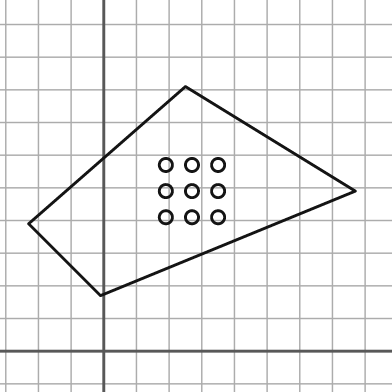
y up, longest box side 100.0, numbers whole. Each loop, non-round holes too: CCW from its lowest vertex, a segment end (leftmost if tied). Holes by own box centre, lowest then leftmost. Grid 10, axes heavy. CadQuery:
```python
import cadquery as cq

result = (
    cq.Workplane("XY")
    .moveTo(-1.0, 17.0)
    .lineTo(77.0, 49.0)
    .lineTo(25.0, 81.0)
    .lineTo(-23.0, 39.0)
    .close()
    .moveTo(19.0, 41.0)
    .circle(2.0)
    .moveTo(27.0, 41.0)
    .circle(2.0)
    .moveTo(35.0, 41.0)
    .circle(2.0)
    .moveTo(19.0, 49.0)
    .circle(2.0)
    .moveTo(27.0, 49.0)
    .circle(2.0)
    .moveTo(35.0, 49.0)
    .circle(2.0)
    .moveTo(19.0, 57.0)
    .circle(2.0)
    .moveTo(27.0, 57.0)
    .circle(2.0)
    .moveTo(35.0, 57.0)
    .circle(2.0)
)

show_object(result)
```